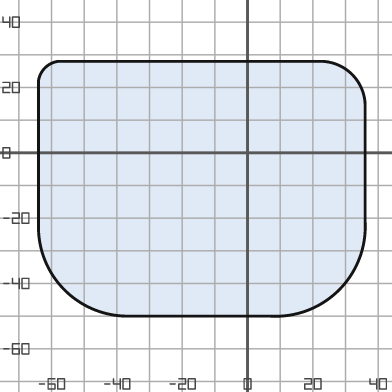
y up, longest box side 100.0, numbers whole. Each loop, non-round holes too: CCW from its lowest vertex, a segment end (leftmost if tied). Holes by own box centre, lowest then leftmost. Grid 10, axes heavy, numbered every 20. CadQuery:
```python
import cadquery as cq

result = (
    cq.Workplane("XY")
    .moveTo(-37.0, -50.0)
    .lineTo(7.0, -50.0)
    .threePointArc((28.0, -42.0), (36.0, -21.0))
    .lineTo(36.0, 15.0)
    .threePointArc((32.0, 24.0), (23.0, 28.0))
    .lineTo(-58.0, 28.0)
    .threePointArc((-62.0, 26.0), (-64.0, 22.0))
    .lineTo(-64.0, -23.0)
    .threePointArc((-56.0, -42.0), (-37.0, -50.0))
    .close()
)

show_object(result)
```